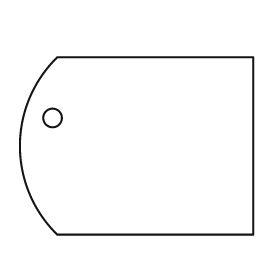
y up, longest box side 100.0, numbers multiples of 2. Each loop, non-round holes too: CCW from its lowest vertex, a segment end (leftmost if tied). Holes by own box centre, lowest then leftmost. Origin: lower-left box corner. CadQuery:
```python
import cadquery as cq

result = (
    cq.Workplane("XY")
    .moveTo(16.0, 0.0)
    .lineTo(100.0, 0.0)
    .lineTo(100.0, 76.0)
    .lineTo(16.0, 76.0)
    .threePointArc((0.0, 38.0), (16.0, 0.0))
    .close()
    .moveTo(14.0, 50.0)
    .circle(4.0)
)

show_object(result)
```